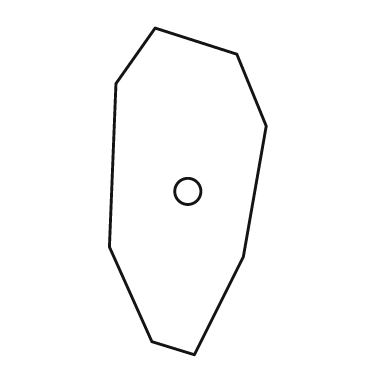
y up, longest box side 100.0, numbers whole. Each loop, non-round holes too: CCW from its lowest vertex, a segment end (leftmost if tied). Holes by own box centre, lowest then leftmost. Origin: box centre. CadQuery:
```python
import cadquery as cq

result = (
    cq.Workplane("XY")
    .moveTo(2.0, -50.0)
    .lineTo(17.0, -20.0)
    .lineTo(24.0, 20.0)
    .lineTo(15.0, 42.0)
    .lineTo(-10.0, 50.0)
    .lineTo(-22.0, 33.0)
    .lineTo(-24.0, -17.0)
    .lineTo(-11.0, -46.0)
    .close()
    .moveTo(0.0, 0.0)
    .circle(4.0)
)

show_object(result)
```